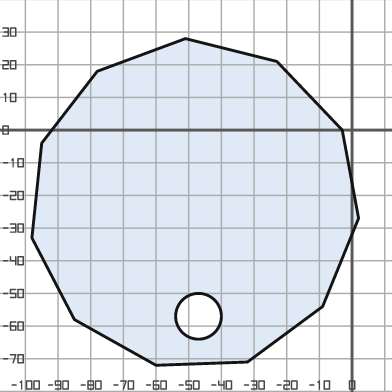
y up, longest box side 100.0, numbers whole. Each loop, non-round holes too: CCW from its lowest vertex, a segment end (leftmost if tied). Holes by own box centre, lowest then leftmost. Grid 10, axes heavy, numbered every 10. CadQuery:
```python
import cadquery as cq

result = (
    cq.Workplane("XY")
    .moveTo(-60.0, -72.0)
    .lineTo(-32.0, -71.0)
    .lineTo(-9.0, -54.0)
    .lineTo(2.0, -27.0)
    .lineTo(-3.0, 0.0)
    .lineTo(-23.0, 21.0)
    .lineTo(-51.0, 28.0)
    .lineTo(-78.0, 18.0)
    .lineTo(-95.0, -4.0)
    .lineTo(-98.0, -33.0)
    .lineTo(-85.0, -58.0)
    .close()
    .moveTo(-47.0, -57.0)
    .circle(7.0)
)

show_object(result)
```